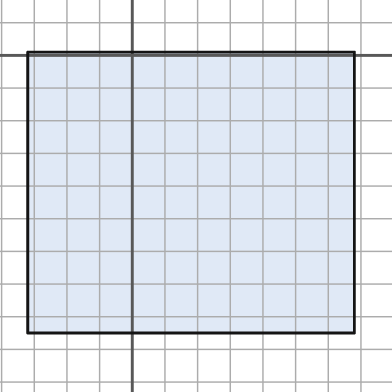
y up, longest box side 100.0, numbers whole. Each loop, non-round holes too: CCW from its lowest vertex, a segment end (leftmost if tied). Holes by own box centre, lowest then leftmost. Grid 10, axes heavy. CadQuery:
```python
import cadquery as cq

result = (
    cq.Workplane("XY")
    .moveTo(-32.0, -85.0)
    .lineTo(68.0, -85.0)
    .lineTo(68.0, 1.0)
    .lineTo(-32.0, 1.0)
    .close()
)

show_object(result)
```